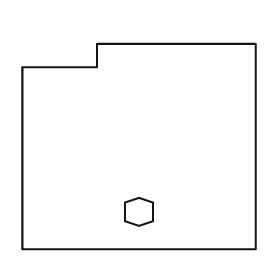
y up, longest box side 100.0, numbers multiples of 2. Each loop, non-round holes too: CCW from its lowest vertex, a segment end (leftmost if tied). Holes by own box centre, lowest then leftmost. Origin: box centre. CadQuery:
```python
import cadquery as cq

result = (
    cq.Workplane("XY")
    .moveTo(-50.0, -44.0)
    .lineTo(50.0, -44.0)
    .lineTo(50.0, 44.0)
    .lineTo(-18.0, 44.0)
    .lineTo(-18.0, 34.0)
    .lineTo(-50.0, 34.0)
    .close()
    .moveTo(0.0, -34.0)
    .lineTo(6.0, -32.0)
    .lineTo(6.0, -24.0)
    .lineTo(0.0, -22.0)
    .lineTo(-6.0, -24.0)
    .lineTo(-6.0, -32.0)
    .close()
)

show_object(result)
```